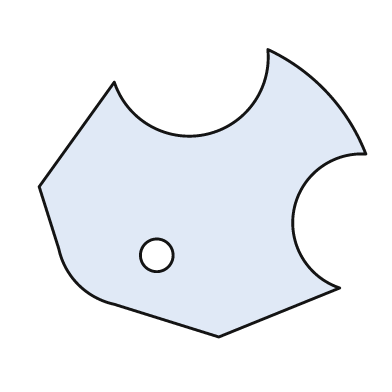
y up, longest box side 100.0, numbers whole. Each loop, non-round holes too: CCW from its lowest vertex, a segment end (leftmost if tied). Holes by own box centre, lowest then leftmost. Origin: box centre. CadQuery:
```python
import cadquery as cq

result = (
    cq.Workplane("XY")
    .moveTo(5.0, -44.0)
    .lineTo(42.0, -29.0)
    .threePointArc((28.0, -5.0), (50.0, 12.0))
    .threePointArc((38.0, 31.0), (20.0, 44.0))
    .threePointArc((1.0, 18.0), (-27.0, 34.0))
    .lineTo(-50.0, 2.0)
    .lineTo(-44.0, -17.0)
    .threePointArc((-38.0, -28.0), (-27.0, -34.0))
    .close()
    .moveTo(-14.0, -19.0)
    .circle(5.0)
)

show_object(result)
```